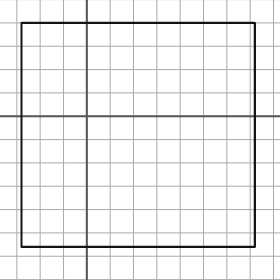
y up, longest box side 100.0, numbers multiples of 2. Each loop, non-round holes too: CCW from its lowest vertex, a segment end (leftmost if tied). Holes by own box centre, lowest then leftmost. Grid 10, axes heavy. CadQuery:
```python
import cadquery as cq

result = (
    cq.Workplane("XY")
    .moveTo(-28.0, -56.0)
    .lineTo(72.0, -56.0)
    .lineTo(72.0, 40.0)
    .lineTo(-28.0, 40.0)
    .close()
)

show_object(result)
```